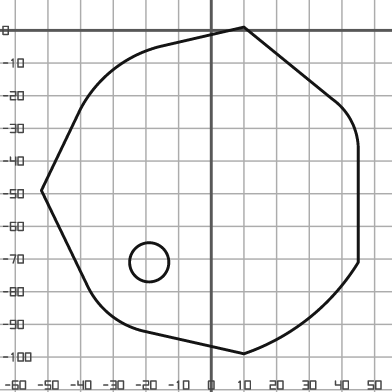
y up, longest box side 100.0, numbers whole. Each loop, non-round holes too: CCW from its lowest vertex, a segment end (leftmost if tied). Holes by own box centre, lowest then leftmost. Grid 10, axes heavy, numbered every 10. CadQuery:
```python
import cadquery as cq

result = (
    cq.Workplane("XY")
    .moveTo(10.0, -99.0)
    .threePointArc((30.0, -88.0), (45.0, -71.0))
    .lineTo(45.0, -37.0)
    .threePointArc((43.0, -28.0), (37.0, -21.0))
    .lineTo(10.0, 1.0)
    .lineTo(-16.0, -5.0)
    .threePointArc((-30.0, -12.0), (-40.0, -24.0))
    .lineTo(-52.0, -49.0)
    .lineTo(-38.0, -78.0)
    .threePointArc((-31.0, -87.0), (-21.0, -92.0))
    .close()
    .moveTo(-19.0, -71.0)
    .circle(6.0)
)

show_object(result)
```